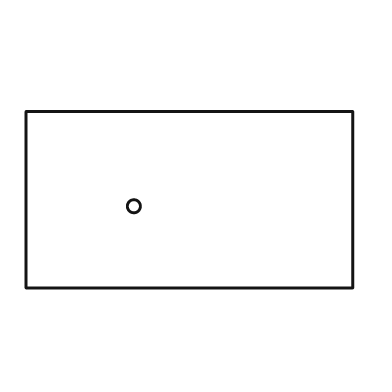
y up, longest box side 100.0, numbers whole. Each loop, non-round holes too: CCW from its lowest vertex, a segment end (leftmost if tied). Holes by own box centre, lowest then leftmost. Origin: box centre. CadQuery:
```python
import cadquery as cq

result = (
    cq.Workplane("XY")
    .moveTo(-50.0, -27.0)
    .lineTo(50.0, -27.0)
    .lineTo(50.0, 27.0)
    .lineTo(-50.0, 27.0)
    .close()
    .moveTo(-17.0, -2.0)
    .circle(2.0)
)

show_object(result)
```